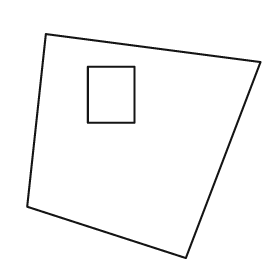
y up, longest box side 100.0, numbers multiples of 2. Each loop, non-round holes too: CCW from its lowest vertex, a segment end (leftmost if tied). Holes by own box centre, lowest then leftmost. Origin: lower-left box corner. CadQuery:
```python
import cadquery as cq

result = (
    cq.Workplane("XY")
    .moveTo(68.0, 0.0)
    .lineTo(100.0, 84.0)
    .lineTo(8.0, 96.0)
    .lineTo(0.0, 22.0)
    .close()
    .moveTo(26.0, 58.0)
    .lineTo(46.0, 58.0)
    .lineTo(46.0, 82.0)
    .lineTo(26.0, 82.0)
    .close()
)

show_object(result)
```